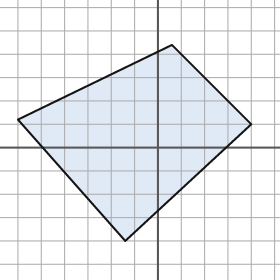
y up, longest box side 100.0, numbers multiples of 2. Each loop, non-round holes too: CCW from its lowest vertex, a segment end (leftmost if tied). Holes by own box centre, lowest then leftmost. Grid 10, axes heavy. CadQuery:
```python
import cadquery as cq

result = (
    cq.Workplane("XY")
    .moveTo(-14.0, -40.0)
    .lineTo(40.0, 10.0)
    .lineTo(6.0, 44.0)
    .lineTo(-60.0, 12.0)
    .close()
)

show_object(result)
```